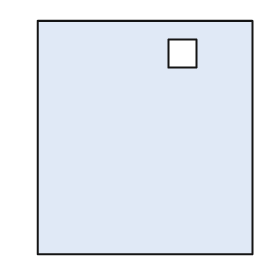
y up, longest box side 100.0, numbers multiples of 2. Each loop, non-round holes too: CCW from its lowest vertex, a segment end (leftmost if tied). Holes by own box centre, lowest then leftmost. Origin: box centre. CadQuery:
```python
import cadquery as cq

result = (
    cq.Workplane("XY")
    .moveTo(-46.0, -50.0)
    .lineTo(46.0, -50.0)
    .lineTo(46.0, 50.0)
    .lineTo(-46.0, 50.0)
    .close()
    .moveTo(10.0, 30.0)
    .lineTo(22.0, 30.0)
    .lineTo(22.0, 42.0)
    .lineTo(10.0, 42.0)
    .close()
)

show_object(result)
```